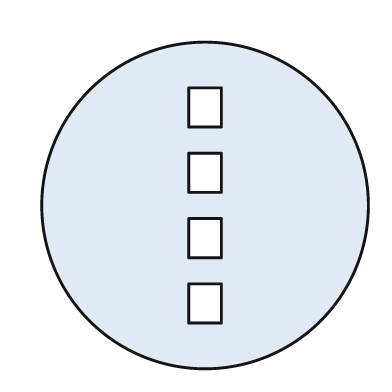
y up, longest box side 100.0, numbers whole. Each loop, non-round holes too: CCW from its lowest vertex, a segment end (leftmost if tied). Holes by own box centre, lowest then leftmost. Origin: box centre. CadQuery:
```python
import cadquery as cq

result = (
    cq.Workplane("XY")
    .moveTo(0.0, 0.0)
    .circle(50.0)
    .moveTo(-5.0, -36.0)
    .lineTo(5.0, -36.0)
    .lineTo(5.0, -24.0)
    .lineTo(-5.0, -24.0)
    .close()
    .moveTo(-5.0, -16.0)
    .lineTo(5.0, -16.0)
    .lineTo(5.0, -4.0)
    .lineTo(-5.0, -4.0)
    .close()
    .moveTo(-5.0, 4.0)
    .lineTo(5.0, 4.0)
    .lineTo(5.0, 16.0)
    .lineTo(-5.0, 16.0)
    .close()
    .moveTo(-5.0, 24.0)
    .lineTo(5.0, 24.0)
    .lineTo(5.0, 36.0)
    .lineTo(-5.0, 36.0)
    .close()
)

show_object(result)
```